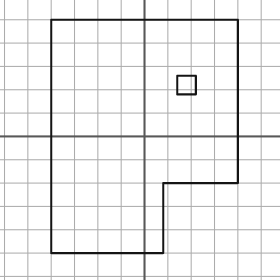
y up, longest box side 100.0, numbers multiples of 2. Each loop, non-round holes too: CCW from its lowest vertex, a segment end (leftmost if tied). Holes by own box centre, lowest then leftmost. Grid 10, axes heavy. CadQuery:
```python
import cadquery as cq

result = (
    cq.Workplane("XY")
    .moveTo(-40.0, -50.0)
    .lineTo(8.0, -50.0)
    .lineTo(8.0, -20.0)
    .lineTo(40.0, -20.0)
    .lineTo(40.0, 50.0)
    .lineTo(-40.0, 50.0)
    .close()
    .moveTo(14.0, 18.0)
    .lineTo(22.0, 18.0)
    .lineTo(22.0, 26.0)
    .lineTo(14.0, 26.0)
    .close()
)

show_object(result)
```